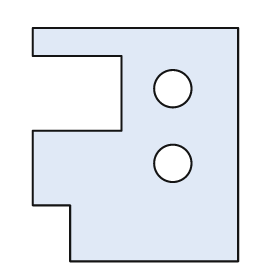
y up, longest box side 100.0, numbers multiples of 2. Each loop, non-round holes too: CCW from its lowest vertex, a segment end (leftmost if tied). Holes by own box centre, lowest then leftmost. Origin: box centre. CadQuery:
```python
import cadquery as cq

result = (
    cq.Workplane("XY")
    .moveTo(-28.0, -50.0)
    .lineTo(44.0, -50.0)
    .lineTo(44.0, 50.0)
    .lineTo(-44.0, 50.0)
    .lineTo(-44.0, 38.0)
    .lineTo(-6.0, 38.0)
    .lineTo(-6.0, 6.0)
    .lineTo(-44.0, 6.0)
    .lineTo(-44.0, -26.0)
    .lineTo(-28.0, -26.0)
    .close()
    .moveTo(16.0, -8.0)
    .circle(8.0)
    .moveTo(16.0, 24.0)
    .circle(8.0)
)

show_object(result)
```